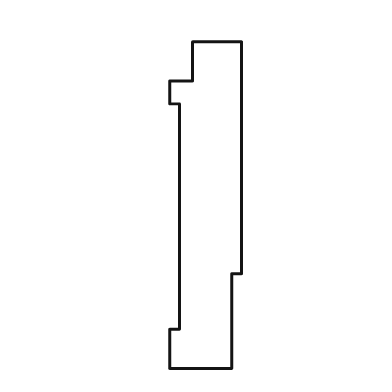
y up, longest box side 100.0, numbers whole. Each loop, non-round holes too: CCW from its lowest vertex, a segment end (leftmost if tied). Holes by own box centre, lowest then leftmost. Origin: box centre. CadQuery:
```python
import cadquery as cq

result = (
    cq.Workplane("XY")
    .moveTo(-11.0, -50.0)
    .lineTo(8.0, -50.0)
    .lineTo(8.0, -21.0)
    .lineTo(11.0, -21.0)
    .lineTo(11.0, 50.0)
    .lineTo(-4.0, 50.0)
    .lineTo(-4.0, 38.0)
    .lineTo(-11.0, 38.0)
    .lineTo(-11.0, 31.0)
    .lineTo(-8.0, 31.0)
    .lineTo(-8.0, -38.0)
    .lineTo(-11.0, -38.0)
    .close()
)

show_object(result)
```